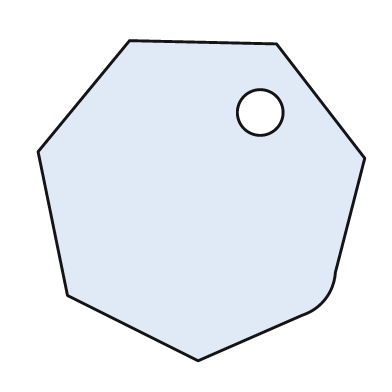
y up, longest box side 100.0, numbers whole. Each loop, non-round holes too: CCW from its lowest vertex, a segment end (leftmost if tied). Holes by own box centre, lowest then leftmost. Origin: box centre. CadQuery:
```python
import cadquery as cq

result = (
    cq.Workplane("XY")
    .moveTo(-1.0, -49.0)
    .lineTo(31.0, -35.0)
    .threePointArc((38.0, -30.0), (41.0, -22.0))
    .lineTo(50.0, 13.0)
    .lineTo(23.0, 48.0)
    .lineTo(-22.0, 49.0)
    .lineTo(-50.0, 15.0)
    .lineTo(-41.0, -29.0)
    .close()
    .moveTo(18.0, 27.0)
    .circle(7.0)
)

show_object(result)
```